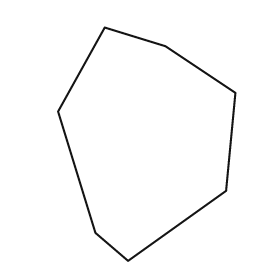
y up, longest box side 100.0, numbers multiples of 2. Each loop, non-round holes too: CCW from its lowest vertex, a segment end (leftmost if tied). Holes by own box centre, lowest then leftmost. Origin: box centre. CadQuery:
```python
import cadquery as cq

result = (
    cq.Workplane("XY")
    .moveTo(-8.0, -50.0)
    .lineTo(34.0, -20.0)
    .lineTo(38.0, 22.0)
    .lineTo(8.0, 42.0)
    .lineTo(-18.0, 50.0)
    .lineTo(-38.0, 14.0)
    .lineTo(-22.0, -38.0)
    .close()
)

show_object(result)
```